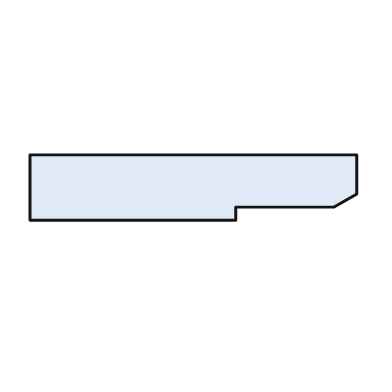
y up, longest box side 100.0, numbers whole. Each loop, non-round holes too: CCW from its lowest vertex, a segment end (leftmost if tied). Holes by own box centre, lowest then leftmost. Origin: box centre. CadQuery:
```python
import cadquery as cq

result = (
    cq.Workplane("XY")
    .moveTo(-50.0, -10.0)
    .lineTo(13.0, -10.0)
    .lineTo(13.0, -6.0)
    .lineTo(43.0, -6.0)
    .lineTo(50.0, -2.0)
    .lineTo(50.0, 10.0)
    .lineTo(-50.0, 10.0)
    .close()
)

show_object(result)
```